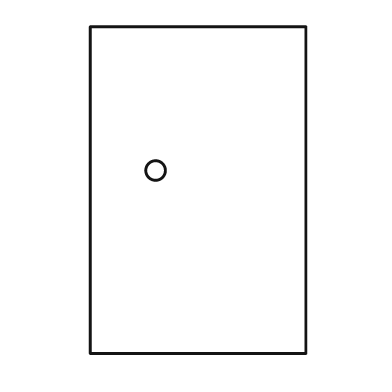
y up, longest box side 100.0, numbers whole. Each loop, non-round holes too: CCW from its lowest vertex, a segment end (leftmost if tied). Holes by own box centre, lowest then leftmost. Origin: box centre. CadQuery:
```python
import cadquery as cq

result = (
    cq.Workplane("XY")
    .moveTo(-33.0, -50.0)
    .lineTo(33.0, -50.0)
    .lineTo(33.0, 50.0)
    .lineTo(-33.0, 50.0)
    .close()
    .moveTo(-13.0, 6.0)
    .circle(3.0)
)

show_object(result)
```